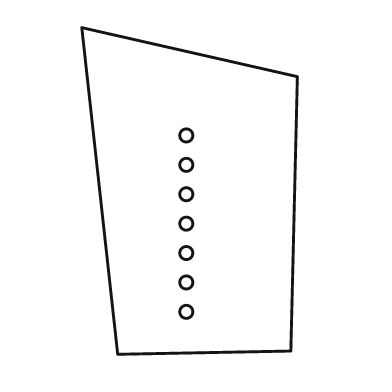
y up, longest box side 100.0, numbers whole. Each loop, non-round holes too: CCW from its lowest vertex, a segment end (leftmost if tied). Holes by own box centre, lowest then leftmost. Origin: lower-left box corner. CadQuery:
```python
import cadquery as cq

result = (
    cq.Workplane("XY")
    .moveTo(11.0, 0.0)
    .lineTo(64.0, 1.0)
    .lineTo(66.0, 85.0)
    .lineTo(0.0, 100.0)
    .close()
    .moveTo(32.0, 13.0)
    .circle(2.0)
    .moveTo(32.0, 22.0)
    .circle(2.0)
    .moveTo(32.0, 31.0)
    .circle(2.0)
    .moveTo(32.0, 40.0)
    .circle(2.0)
    .moveTo(32.0, 49.0)
    .circle(2.0)
    .moveTo(32.0, 58.0)
    .circle(2.0)
    .moveTo(32.0, 67.0)
    .circle(2.0)
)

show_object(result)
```